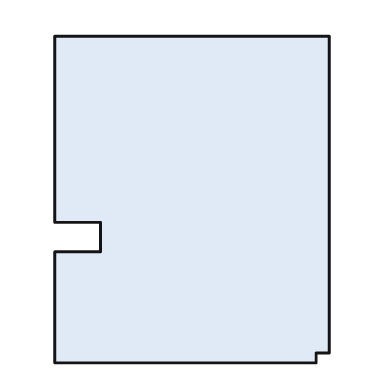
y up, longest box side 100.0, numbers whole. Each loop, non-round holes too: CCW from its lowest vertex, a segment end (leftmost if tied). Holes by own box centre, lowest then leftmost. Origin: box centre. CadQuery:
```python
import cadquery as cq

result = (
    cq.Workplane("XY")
    .moveTo(-42.0, -50.0)
    .lineTo(38.0, -50.0)
    .lineTo(38.0, -47.0)
    .lineTo(42.0, -47.0)
    .lineTo(42.0, 50.0)
    .lineTo(-42.0, 50.0)
    .lineTo(-42.0, -7.0)
    .lineTo(-28.0, -7.0)
    .lineTo(-28.0, -16.0)
    .lineTo(-42.0, -16.0)
    .close()
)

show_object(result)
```